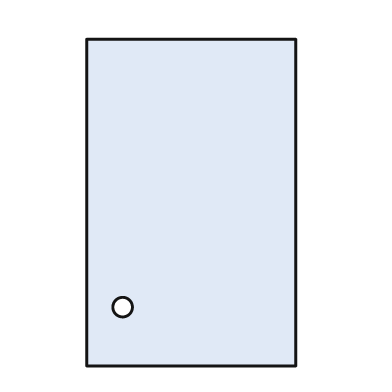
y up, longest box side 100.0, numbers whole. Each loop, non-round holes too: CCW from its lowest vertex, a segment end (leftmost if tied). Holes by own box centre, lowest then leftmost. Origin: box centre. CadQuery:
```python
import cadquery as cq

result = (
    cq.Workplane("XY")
    .moveTo(-32.0, -50.0)
    .lineTo(32.0, -50.0)
    .lineTo(32.0, 50.0)
    .lineTo(-32.0, 50.0)
    .close()
    .moveTo(-21.0, -32.0)
    .circle(3.0)
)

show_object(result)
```